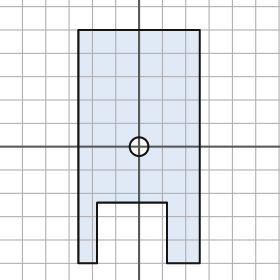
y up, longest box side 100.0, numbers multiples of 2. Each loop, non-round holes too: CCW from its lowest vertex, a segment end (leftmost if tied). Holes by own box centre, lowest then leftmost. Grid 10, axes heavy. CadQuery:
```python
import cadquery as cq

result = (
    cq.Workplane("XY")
    .moveTo(-26.0, -50.0)
    .lineTo(-18.0, -50.0)
    .lineTo(-18.0, -24.0)
    .lineTo(12.0, -24.0)
    .lineTo(12.0, -50.0)
    .lineTo(26.0, -50.0)
    .lineTo(26.0, 50.0)
    .lineTo(-26.0, 50.0)
    .close()
    .moveTo(0.0, 0.0)
    .circle(4.0)
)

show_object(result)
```